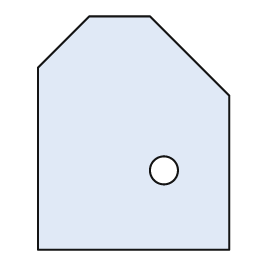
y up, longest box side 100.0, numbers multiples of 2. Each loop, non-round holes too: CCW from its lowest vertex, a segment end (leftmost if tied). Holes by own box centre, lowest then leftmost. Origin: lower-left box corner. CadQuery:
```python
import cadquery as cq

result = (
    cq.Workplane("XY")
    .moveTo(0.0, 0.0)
    .lineTo(82.0, 0.0)
    .lineTo(82.0, 66.0)
    .lineTo(48.0, 100.0)
    .lineTo(22.0, 100.0)
    .lineTo(0.0, 78.0)
    .close()
    .moveTo(54.0, 34.0)
    .circle(6.0)
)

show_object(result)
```